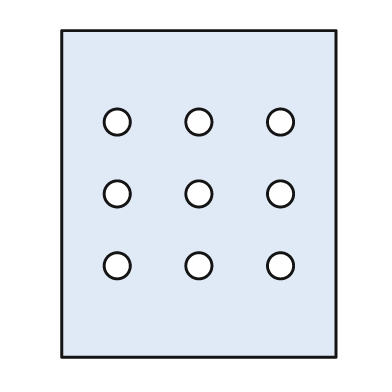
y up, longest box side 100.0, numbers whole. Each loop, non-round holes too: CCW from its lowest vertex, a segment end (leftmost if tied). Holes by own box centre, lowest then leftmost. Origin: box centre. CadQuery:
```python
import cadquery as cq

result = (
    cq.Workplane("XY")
    .moveTo(-42.0, -50.0)
    .lineTo(42.0, -50.0)
    .lineTo(42.0, 50.0)
    .lineTo(-42.0, 50.0)
    .close()
    .moveTo(-25.0, -22.0)
    .circle(4.0)
    .moveTo(0.0, -22.0)
    .circle(4.0)
    .moveTo(25.0, -22.0)
    .circle(4.0)
    .moveTo(-25.0, 0.0)
    .circle(4.0)
    .moveTo(0.0, 0.0)
    .circle(4.0)
    .moveTo(25.0, 0.0)
    .circle(4.0)
    .moveTo(-25.0, 22.0)
    .circle(4.0)
    .moveTo(0.0, 22.0)
    .circle(4.0)
    .moveTo(25.0, 22.0)
    .circle(4.0)
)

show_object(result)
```